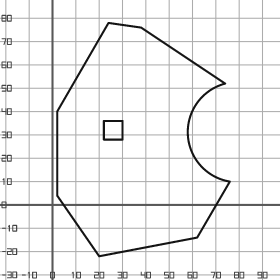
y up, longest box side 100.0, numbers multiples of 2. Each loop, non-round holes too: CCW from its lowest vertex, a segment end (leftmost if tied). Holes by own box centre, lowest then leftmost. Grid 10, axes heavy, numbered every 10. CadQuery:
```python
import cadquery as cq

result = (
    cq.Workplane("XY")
    .moveTo(20.0, -22.0)
    .lineTo(62.0, -14.0)
    .lineTo(76.0, 10.0)
    .threePointArc((58.0, 30.0), (74.0, 52.0))
    .lineTo(38.0, 76.0)
    .lineTo(24.0, 78.0)
    .lineTo(2.0, 40.0)
    .lineTo(2.0, 4.0)
    .close()
    .moveTo(22.0, 28.0)
    .lineTo(30.0, 28.0)
    .lineTo(30.0, 36.0)
    .lineTo(22.0, 36.0)
    .close()
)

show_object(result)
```